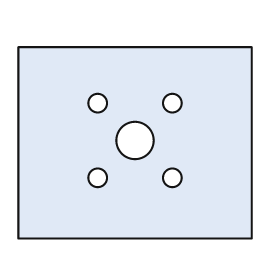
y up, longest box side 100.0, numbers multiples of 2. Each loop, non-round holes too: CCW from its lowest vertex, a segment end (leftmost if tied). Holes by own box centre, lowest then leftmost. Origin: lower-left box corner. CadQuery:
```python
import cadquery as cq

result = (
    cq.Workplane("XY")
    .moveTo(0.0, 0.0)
    .lineTo(100.0, 0.0)
    .lineTo(100.0, 82.0)
    .lineTo(0.0, 82.0)
    .close()
    .moveTo(34.0, 26.0)
    .circle(4.0)
    .moveTo(66.0, 26.0)
    .circle(4.0)
    .moveTo(50.0, 42.0)
    .circle(8.0)
    .moveTo(34.0, 58.0)
    .circle(4.0)
    .moveTo(66.0, 58.0)
    .circle(4.0)
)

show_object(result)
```